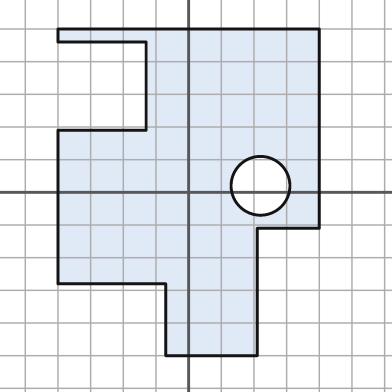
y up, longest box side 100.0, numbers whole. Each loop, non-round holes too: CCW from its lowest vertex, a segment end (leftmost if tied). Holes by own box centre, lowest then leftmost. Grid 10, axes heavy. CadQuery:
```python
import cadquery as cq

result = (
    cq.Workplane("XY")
    .moveTo(-7.0, -50.0)
    .lineTo(21.0, -50.0)
    .lineTo(21.0, -11.0)
    .lineTo(40.0, -11.0)
    .lineTo(40.0, 50.0)
    .lineTo(-40.0, 50.0)
    .lineTo(-40.0, 46.0)
    .lineTo(-13.0, 46.0)
    .lineTo(-13.0, 19.0)
    .lineTo(-40.0, 19.0)
    .lineTo(-40.0, -28.0)
    .lineTo(-7.0, -28.0)
    .close()
    .moveTo(22.0, 2.0)
    .circle(9.0)
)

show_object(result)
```